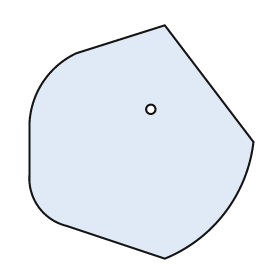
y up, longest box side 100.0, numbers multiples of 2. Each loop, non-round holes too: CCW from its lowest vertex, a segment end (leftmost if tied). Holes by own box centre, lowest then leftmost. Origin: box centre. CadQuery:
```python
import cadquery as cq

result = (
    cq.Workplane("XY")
    .moveTo(10.0, -50.0)
    .threePointArc((36.0, -30.0), (48.0, 0.0))
    .lineTo(10.0, 50.0)
    .lineTo(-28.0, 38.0)
    .threePointArc((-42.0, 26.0), (-48.0, 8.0))
    .lineTo(-48.0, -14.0)
    .threePointArc((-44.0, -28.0), (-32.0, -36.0))
    .close()
    .moveTo(4.0, 14.0)
    .circle(2.0)
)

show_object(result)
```